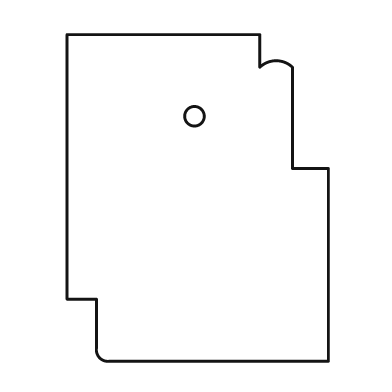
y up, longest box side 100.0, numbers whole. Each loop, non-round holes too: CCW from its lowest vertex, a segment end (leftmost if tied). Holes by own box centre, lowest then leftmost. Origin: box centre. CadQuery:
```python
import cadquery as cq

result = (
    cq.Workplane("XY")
    .moveTo(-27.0, -50.0)
    .lineTo(40.0, -50.0)
    .lineTo(40.0, 9.0)
    .lineTo(29.0, 9.0)
    .lineTo(29.0, 40.0)
    .threePointArc((24.0, 42.0), (19.0, 40.0))
    .lineTo(19.0, 50.0)
    .lineTo(-40.0, 50.0)
    .lineTo(-40.0, -31.0)
    .lineTo(-31.0, -31.0)
    .lineTo(-31.0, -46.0)
    .threePointArc((-30.0, -49.0), (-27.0, -50.0))
    .close()
    .moveTo(-1.0, 25.0)
    .circle(3.0)
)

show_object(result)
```